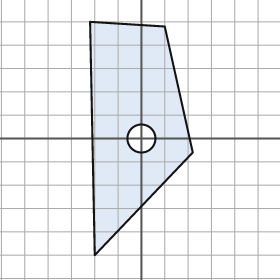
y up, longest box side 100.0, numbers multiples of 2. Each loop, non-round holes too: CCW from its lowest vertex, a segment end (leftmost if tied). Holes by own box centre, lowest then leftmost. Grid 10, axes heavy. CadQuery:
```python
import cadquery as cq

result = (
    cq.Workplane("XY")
    .moveTo(-20.0, -50.0)
    .lineTo(22.0, -6.0)
    .lineTo(10.0, 48.0)
    .lineTo(-22.0, 50.0)
    .close()
    .moveTo(0.0, 0.0)
    .circle(6.0)
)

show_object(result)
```